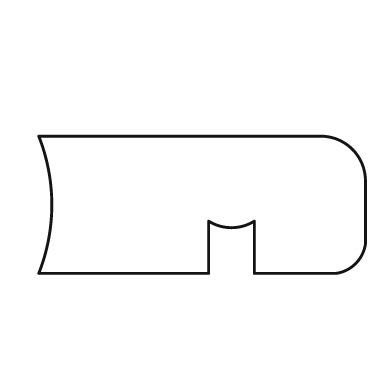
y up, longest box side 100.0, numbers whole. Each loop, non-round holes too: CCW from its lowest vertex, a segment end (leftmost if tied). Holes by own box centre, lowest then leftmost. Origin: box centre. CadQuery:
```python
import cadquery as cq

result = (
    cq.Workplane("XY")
    .moveTo(-50.0, -21.0)
    .lineTo(2.0, -21.0)
    .lineTo(2.0, -5.0)
    .threePointArc((9.0, -7.0), (16.0, -5.0))
    .lineTo(16.0, -21.0)
    .lineTo(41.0, -21.0)
    .threePointArc((47.0, -18.0), (50.0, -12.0))
    .lineTo(50.0, 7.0)
    .threePointArc((46.0, 17.0), (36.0, 21.0))
    .lineTo(-50.0, 21.0)
    .threePointArc((-46.0, 0.0), (-50.0, -21.0))
    .close()
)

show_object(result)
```